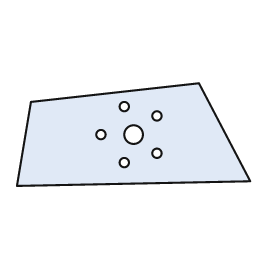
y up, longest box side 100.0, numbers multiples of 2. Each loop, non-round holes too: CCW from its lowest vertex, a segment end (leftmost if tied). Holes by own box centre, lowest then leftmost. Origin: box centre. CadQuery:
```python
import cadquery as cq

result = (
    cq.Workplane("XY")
    .moveTo(-50.0, -22.0)
    .lineTo(50.0, -20.0)
    .lineTo(28.0, 22.0)
    .lineTo(-44.0, 14.0)
    .close()
    .moveTo(-4.0, -12.0)
    .circle(2.0)
    .moveTo(10.0, -8.0)
    .circle(2.0)
    .moveTo(-14.0, 0.0)
    .circle(2.0)
    .moveTo(0.0, 0.0)
    .circle(4.0)
    .moveTo(10.0, 8.0)
    .circle(2.0)
    .moveTo(-4.0, 12.0)
    .circle(2.0)
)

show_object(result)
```